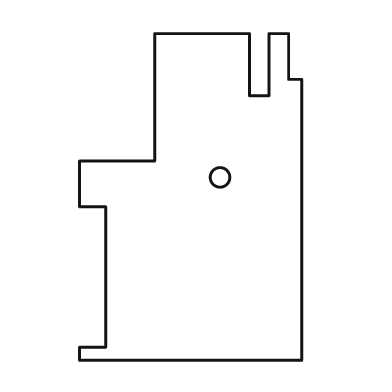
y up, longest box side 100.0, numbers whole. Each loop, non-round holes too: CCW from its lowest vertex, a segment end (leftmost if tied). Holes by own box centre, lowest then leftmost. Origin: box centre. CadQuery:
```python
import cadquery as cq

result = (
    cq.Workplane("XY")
    .moveTo(-34.0, -50.0)
    .lineTo(34.0, -50.0)
    .lineTo(34.0, 36.0)
    .lineTo(30.0, 36.0)
    .lineTo(30.0, 50.0)
    .lineTo(24.0, 50.0)
    .lineTo(24.0, 31.0)
    .lineTo(18.0, 31.0)
    .lineTo(18.0, 50.0)
    .lineTo(-11.0, 50.0)
    .lineTo(-11.0, 11.0)
    .lineTo(-34.0, 11.0)
    .lineTo(-34.0, -3.0)
    .lineTo(-26.0, -3.0)
    .lineTo(-26.0, -46.0)
    .lineTo(-34.0, -46.0)
    .close()
    .moveTo(9.0, 6.0)
    .circle(3.0)
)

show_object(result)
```